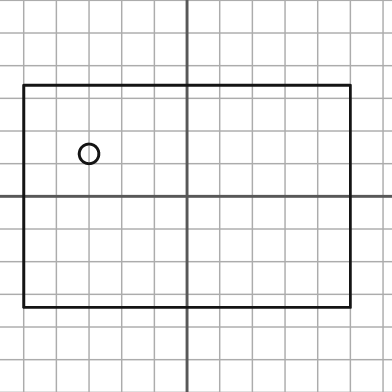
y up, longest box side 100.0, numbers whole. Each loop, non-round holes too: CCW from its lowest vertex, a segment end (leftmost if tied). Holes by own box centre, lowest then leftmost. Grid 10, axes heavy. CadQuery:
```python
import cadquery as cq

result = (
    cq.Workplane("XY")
    .moveTo(-50.0, -34.0)
    .lineTo(50.0, -34.0)
    .lineTo(50.0, 34.0)
    .lineTo(-50.0, 34.0)
    .close()
    .moveTo(-30.0, 13.0)
    .circle(3.0)
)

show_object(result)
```